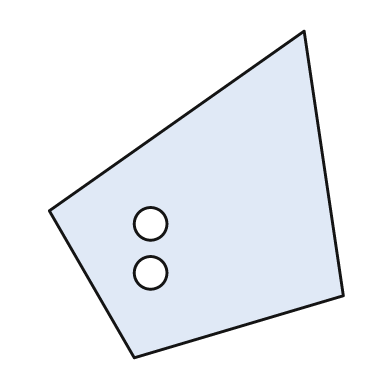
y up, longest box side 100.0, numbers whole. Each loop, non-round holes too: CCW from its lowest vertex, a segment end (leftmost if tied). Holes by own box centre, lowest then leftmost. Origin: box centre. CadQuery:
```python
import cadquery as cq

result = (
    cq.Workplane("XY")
    .moveTo(-19.0, -50.0)
    .lineTo(45.0, -31.0)
    .lineTo(33.0, 50.0)
    .lineTo(-45.0, -5.0)
    .close()
    .moveTo(-14.0, -24.0)
    .circle(5.0)
    .moveTo(-14.0, -9.0)
    .circle(5.0)
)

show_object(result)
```